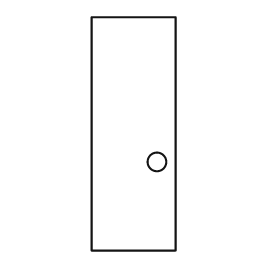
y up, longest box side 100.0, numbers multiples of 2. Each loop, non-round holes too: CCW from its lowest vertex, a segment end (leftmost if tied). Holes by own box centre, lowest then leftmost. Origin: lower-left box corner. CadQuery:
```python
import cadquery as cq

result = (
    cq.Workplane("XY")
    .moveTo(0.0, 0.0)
    .lineTo(36.0, 0.0)
    .lineTo(36.0, 100.0)
    .lineTo(0.0, 100.0)
    .close()
    .moveTo(28.0, 38.0)
    .circle(4.0)
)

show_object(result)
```